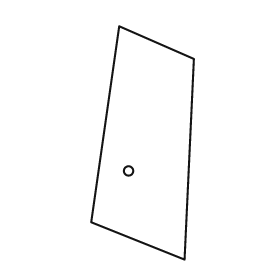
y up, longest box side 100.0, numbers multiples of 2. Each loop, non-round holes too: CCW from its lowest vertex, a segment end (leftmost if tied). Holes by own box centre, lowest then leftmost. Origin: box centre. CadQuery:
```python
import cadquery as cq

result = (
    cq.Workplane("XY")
    .moveTo(18.0, -50.0)
    .lineTo(22.0, 36.0)
    .lineTo(-10.0, 50.0)
    .lineTo(-22.0, -34.0)
    .close()
    .moveTo(-6.0, -12.0)
    .circle(2.0)
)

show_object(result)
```